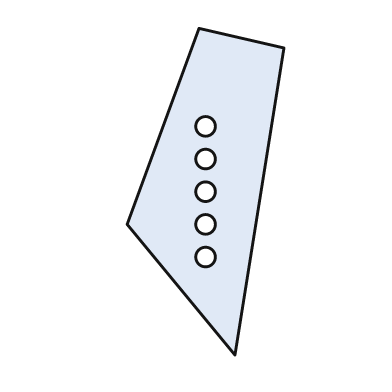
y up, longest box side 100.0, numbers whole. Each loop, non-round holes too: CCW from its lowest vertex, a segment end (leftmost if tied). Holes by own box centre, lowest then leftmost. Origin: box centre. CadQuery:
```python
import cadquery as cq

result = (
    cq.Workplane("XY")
    .moveTo(9.0, -50.0)
    .lineTo(24.0, 44.0)
    .lineTo(-2.0, 50.0)
    .lineTo(-24.0, -10.0)
    .close()
    .moveTo(0.0, -20.0)
    .circle(3.0)
    .moveTo(0.0, -10.0)
    .circle(3.0)
    .moveTo(0.0, 0.0)
    .circle(3.0)
    .moveTo(0.0, 10.0)
    .circle(3.0)
    .moveTo(0.0, 20.0)
    .circle(3.0)
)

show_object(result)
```